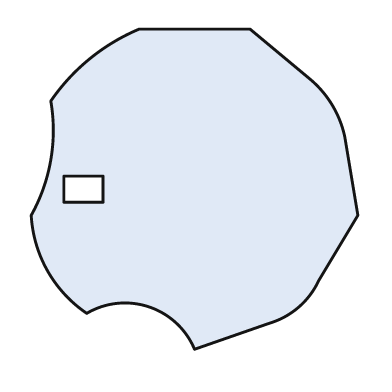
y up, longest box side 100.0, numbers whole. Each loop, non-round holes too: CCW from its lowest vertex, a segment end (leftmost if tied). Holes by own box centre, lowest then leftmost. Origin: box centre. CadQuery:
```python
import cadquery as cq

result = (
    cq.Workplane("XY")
    .moveTo(0.0, -49.0)
    .lineTo(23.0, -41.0)
    .threePointArc((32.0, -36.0), (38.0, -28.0))
    .lineTo(50.0, -8.0)
    .lineTo(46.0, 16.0)
    .threePointArc((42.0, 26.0), (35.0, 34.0))
    .lineTo(17.0, 49.0)
    .lineTo(-17.0, 49.0)
    .threePointArc((-32.0, 40.0), (-44.0, 27.0))
    .threePointArc((-44.0, 9.0), (-50.0, -8.0))
    .threePointArc((-45.0, -25.0), (-33.0, -38.0))
    .threePointArc((-14.0, -36.0), (0.0, -49.0))
    .close()
    .moveTo(-40.0, -4.0)
    .lineTo(-28.0, -4.0)
    .lineTo(-28.0, 4.0)
    .lineTo(-40.0, 4.0)
    .close()
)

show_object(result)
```